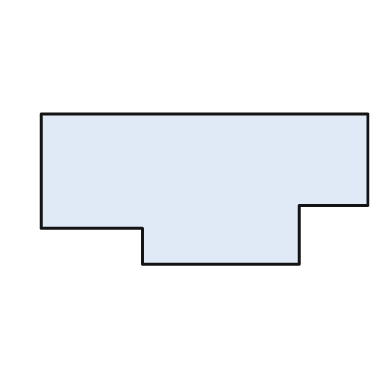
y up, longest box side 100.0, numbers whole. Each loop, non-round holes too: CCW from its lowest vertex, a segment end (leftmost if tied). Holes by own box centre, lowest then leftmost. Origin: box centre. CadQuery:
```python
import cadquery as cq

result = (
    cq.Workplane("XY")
    .moveTo(-19.0, -23.0)
    .lineTo(29.0, -23.0)
    .lineTo(29.0, -5.0)
    .lineTo(50.0, -5.0)
    .lineTo(50.0, 23.0)
    .lineTo(-50.0, 23.0)
    .lineTo(-50.0, -12.0)
    .lineTo(-19.0, -12.0)
    .close()
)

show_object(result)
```